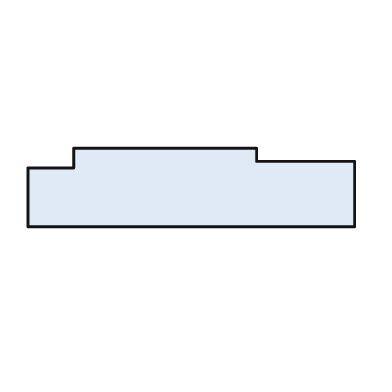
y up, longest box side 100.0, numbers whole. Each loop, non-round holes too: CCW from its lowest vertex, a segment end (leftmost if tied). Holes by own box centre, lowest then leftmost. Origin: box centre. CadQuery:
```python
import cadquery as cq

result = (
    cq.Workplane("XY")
    .moveTo(-50.0, -12.0)
    .lineTo(50.0, -12.0)
    .lineTo(50.0, 8.0)
    .lineTo(20.0, 8.0)
    .lineTo(20.0, 12.0)
    .lineTo(-36.0, 12.0)
    .lineTo(-36.0, 6.0)
    .lineTo(-50.0, 6.0)
    .close()
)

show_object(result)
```